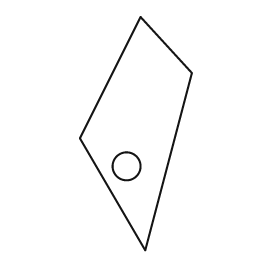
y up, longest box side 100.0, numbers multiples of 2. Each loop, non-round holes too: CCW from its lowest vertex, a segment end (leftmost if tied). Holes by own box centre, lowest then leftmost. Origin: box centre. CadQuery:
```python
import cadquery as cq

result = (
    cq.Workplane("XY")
    .moveTo(4.0, -50.0)
    .lineTo(24.0, 26.0)
    .lineTo(2.0, 50.0)
    .lineTo(-24.0, -2.0)
    .close()
    .moveTo(-4.0, -14.0)
    .circle(6.0)
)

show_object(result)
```